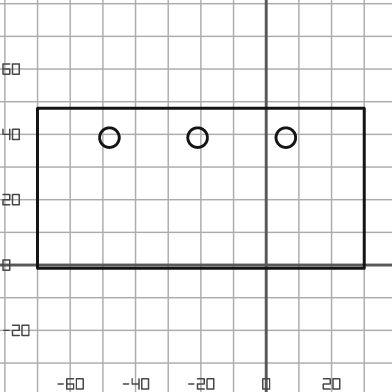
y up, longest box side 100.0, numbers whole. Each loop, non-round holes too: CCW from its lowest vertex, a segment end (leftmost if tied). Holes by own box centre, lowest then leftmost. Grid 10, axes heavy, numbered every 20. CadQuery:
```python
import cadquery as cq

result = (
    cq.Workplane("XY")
    .moveTo(-70.0, -1.0)
    .lineTo(30.0, -1.0)
    .lineTo(30.0, 48.0)
    .lineTo(-70.0, 48.0)
    .close()
    .moveTo(-48.0, 39.0)
    .circle(3.0)
    .moveTo(-21.0, 39.0)
    .circle(3.0)
    .moveTo(6.0, 39.0)
    .circle(3.0)
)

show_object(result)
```